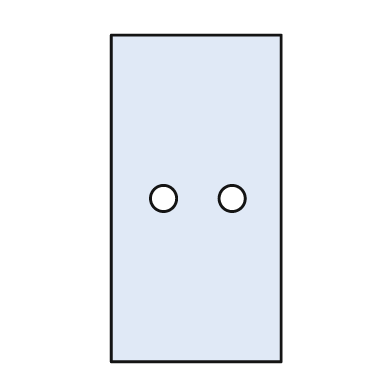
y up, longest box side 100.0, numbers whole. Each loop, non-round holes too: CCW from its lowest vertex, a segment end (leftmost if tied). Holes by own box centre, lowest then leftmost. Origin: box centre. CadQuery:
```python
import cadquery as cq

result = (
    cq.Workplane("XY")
    .moveTo(-26.0, -50.0)
    .lineTo(26.0, -50.0)
    .lineTo(26.0, 50.0)
    .lineTo(-26.0, 50.0)
    .close()
    .moveTo(-10.0, 0.0)
    .circle(4.0)
    .moveTo(11.0, 0.0)
    .circle(4.0)
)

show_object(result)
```